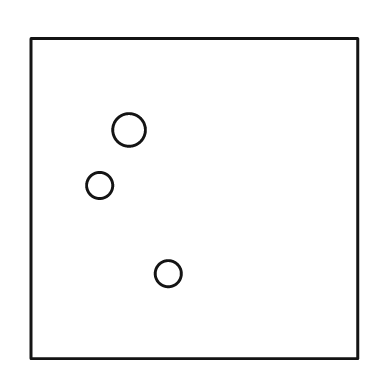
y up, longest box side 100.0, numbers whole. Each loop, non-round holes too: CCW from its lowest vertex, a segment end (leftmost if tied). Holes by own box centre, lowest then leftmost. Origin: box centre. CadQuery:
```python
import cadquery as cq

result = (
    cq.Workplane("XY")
    .moveTo(-50.0, -49.0)
    .lineTo(50.0, -49.0)
    .lineTo(50.0, 49.0)
    .lineTo(-50.0, 49.0)
    .close()
    .moveTo(-8.0, -23.0)
    .circle(4.0)
    .moveTo(-29.0, 4.0)
    .circle(4.0)
    .moveTo(-20.0, 21.0)
    .circle(5.0)
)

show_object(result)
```